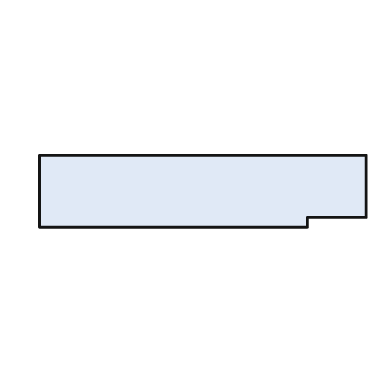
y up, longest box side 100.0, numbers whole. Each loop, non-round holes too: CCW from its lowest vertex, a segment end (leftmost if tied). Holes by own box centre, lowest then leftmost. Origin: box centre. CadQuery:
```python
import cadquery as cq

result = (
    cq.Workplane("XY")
    .moveTo(-50.0, -11.0)
    .lineTo(32.0, -11.0)
    .lineTo(32.0, -8.0)
    .lineTo(50.0, -8.0)
    .lineTo(50.0, 11.0)
    .lineTo(-50.0, 11.0)
    .close()
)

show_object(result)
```